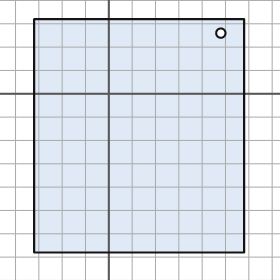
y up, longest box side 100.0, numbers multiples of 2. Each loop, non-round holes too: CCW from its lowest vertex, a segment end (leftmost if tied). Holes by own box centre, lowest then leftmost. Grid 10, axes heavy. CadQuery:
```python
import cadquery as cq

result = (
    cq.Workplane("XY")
    .moveTo(-32.0, -68.0)
    .lineTo(58.0, -68.0)
    .lineTo(58.0, 32.0)
    .lineTo(-32.0, 32.0)
    .close()
    .moveTo(48.0, 26.0)
    .circle(2.0)
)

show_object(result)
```